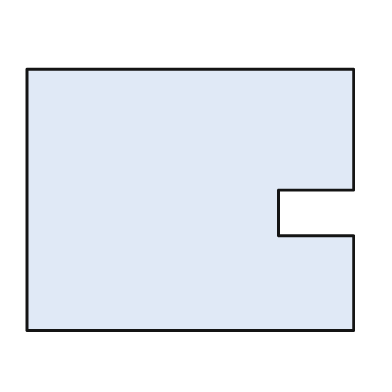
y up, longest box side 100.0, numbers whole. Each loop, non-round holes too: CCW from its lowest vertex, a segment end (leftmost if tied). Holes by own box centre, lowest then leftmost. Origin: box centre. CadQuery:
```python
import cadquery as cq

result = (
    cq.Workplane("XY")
    .moveTo(-50.0, -40.0)
    .lineTo(50.0, -40.0)
    .lineTo(50.0, -11.0)
    .lineTo(27.0, -11.0)
    .lineTo(27.0, 3.0)
    .lineTo(50.0, 3.0)
    .lineTo(50.0, 40.0)
    .lineTo(-50.0, 40.0)
    .close()
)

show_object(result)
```